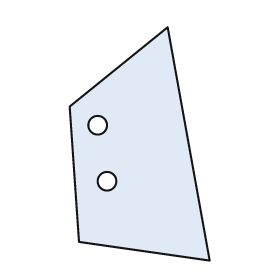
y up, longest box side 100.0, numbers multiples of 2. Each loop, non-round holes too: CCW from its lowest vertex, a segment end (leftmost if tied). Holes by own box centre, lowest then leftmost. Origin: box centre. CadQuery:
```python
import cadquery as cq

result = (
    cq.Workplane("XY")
    .moveTo(30.0, -50.0)
    .lineTo(12.0, 50.0)
    .lineTo(-30.0, 16.0)
    .lineTo(-26.0, -42.0)
    .close()
    .moveTo(-14.0, -16.0)
    .circle(4.0)
    .moveTo(-18.0, 8.0)
    .circle(4.0)
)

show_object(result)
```